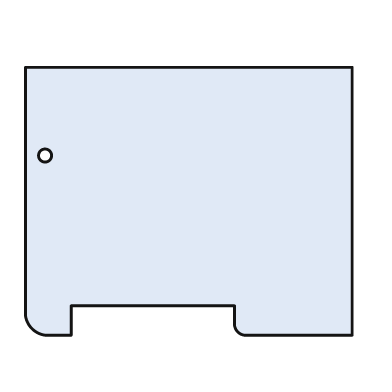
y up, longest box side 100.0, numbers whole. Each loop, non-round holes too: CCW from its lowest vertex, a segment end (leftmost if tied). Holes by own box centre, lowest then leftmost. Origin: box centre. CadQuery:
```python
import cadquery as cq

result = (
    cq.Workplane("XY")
    .moveTo(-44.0, -41.0)
    .lineTo(-36.0, -41.0)
    .lineTo(-36.0, -32.0)
    .lineTo(14.0, -32.0)
    .lineTo(14.0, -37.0)
    .threePointArc((15.0, -40.0), (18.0, -41.0))
    .lineTo(50.0, -41.0)
    .lineTo(50.0, 41.0)
    .lineTo(-50.0, 41.0)
    .lineTo(-50.0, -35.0)
    .threePointArc((-48.0, -39.0), (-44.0, -41.0))
    .close()
    .moveTo(-44.0, 14.0)
    .circle(2.0)
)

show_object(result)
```